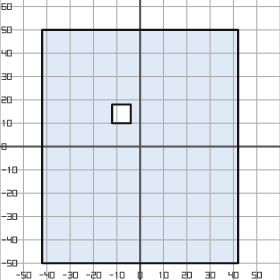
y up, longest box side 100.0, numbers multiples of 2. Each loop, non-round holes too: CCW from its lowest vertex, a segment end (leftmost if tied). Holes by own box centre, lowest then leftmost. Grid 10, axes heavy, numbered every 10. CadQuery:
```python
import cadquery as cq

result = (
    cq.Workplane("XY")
    .moveTo(-42.0, -50.0)
    .lineTo(42.0, -50.0)
    .lineTo(42.0, 50.0)
    .lineTo(-42.0, 50.0)
    .close()
    .moveTo(-12.0, 10.0)
    .lineTo(-4.0, 10.0)
    .lineTo(-4.0, 18.0)
    .lineTo(-12.0, 18.0)
    .close()
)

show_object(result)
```